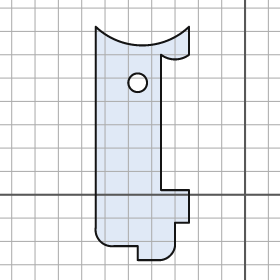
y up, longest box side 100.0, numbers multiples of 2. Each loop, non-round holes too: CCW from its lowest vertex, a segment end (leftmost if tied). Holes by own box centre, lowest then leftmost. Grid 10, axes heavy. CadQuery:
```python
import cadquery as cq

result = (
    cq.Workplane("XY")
    .moveTo(-46.0, -28.0)
    .lineTo(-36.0, -28.0)
    .threePointArc((-32.0, -26.0), (-30.0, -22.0))
    .lineTo(-30.0, -12.0)
    .lineTo(-24.0, -12.0)
    .lineTo(-24.0, 2.0)
    .lineTo(-36.0, 2.0)
    .lineTo(-36.0, 60.0)
    .threePointArc((-30.0, 58.0), (-24.0, 60.0))
    .lineTo(-24.0, 72.0)
    .threePointArc((-44.0, 64.0), (-64.0, 72.0))
    .lineTo(-64.0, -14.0)
    .threePointArc((-62.0, -20.0), (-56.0, -22.0))
    .lineTo(-46.0, -22.0)
    .close()
    .moveTo(-46.0, 48.0)
    .circle(4.0)
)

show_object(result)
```